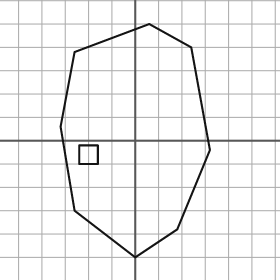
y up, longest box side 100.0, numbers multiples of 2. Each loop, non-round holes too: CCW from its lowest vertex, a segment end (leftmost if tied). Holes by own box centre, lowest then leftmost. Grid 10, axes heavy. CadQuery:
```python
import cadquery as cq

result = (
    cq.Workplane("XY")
    .moveTo(0.0, -50.0)
    .lineTo(18.0, -38.0)
    .lineTo(32.0, -4.0)
    .lineTo(24.0, 40.0)
    .lineTo(6.0, 50.0)
    .lineTo(-26.0, 38.0)
    .lineTo(-32.0, 6.0)
    .lineTo(-26.0, -30.0)
    .close()
    .moveTo(-24.0, -10.0)
    .lineTo(-16.0, -10.0)
    .lineTo(-16.0, -2.0)
    .lineTo(-24.0, -2.0)
    .close()
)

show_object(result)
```